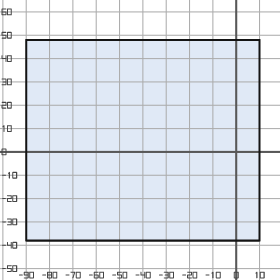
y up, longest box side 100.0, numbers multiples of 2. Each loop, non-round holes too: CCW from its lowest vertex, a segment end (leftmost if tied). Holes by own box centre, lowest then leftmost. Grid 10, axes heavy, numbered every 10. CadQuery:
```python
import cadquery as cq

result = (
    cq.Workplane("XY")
    .moveTo(-90.0, -38.0)
    .lineTo(10.0, -38.0)
    .lineTo(10.0, 48.0)
    .lineTo(-90.0, 48.0)
    .close()
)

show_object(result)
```